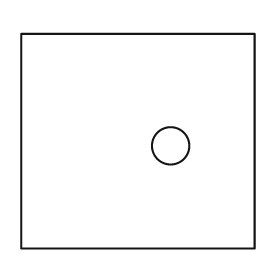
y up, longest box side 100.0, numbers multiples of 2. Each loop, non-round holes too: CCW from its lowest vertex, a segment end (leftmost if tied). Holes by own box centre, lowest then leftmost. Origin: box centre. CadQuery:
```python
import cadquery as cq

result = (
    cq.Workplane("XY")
    .moveTo(-50.0, -46.0)
    .lineTo(50.0, -46.0)
    .lineTo(50.0, 46.0)
    .lineTo(-50.0, 46.0)
    .close()
    .moveTo(14.0, -2.0)
    .circle(8.0)
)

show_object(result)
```